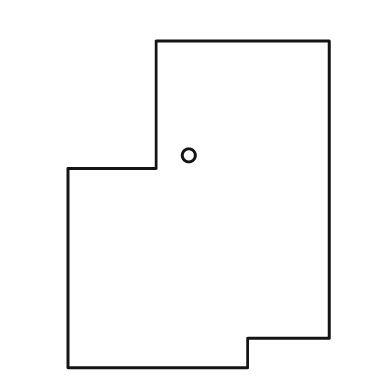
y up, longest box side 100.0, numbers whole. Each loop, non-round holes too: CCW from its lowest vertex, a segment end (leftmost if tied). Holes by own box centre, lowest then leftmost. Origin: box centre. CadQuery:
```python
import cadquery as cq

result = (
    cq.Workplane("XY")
    .moveTo(-40.0, -50.0)
    .lineTo(15.0, -50.0)
    .lineTo(15.0, -41.0)
    .lineTo(40.0, -41.0)
    .lineTo(40.0, 50.0)
    .lineTo(-13.0, 50.0)
    .lineTo(-13.0, 11.0)
    .lineTo(-40.0, 11.0)
    .close()
    .moveTo(-3.0, 15.0)
    .circle(2.0)
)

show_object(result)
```